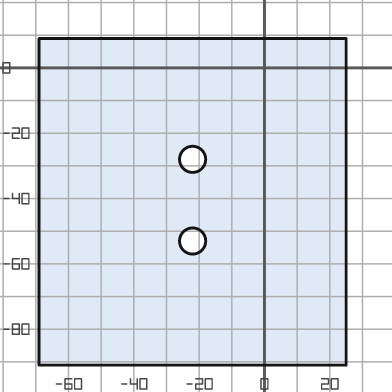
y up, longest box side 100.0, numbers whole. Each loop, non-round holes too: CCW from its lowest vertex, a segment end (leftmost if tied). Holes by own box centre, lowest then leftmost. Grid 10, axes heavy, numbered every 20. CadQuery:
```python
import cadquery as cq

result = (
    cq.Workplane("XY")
    .moveTo(-69.0, -91.0)
    .lineTo(25.0, -91.0)
    .lineTo(25.0, 9.0)
    .lineTo(-69.0, 9.0)
    .close()
    .moveTo(-22.0, -53.0)
    .circle(4.0)
    .moveTo(-22.0, -28.0)
    .circle(4.0)
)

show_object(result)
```